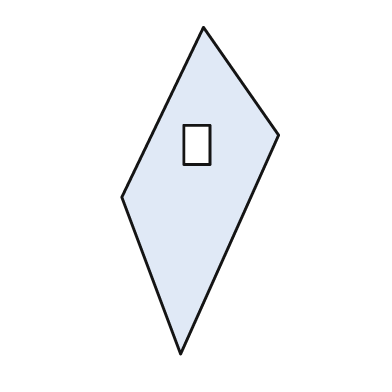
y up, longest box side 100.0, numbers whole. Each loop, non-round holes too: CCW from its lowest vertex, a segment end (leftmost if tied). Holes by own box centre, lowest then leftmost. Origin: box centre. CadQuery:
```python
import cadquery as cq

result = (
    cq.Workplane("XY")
    .moveTo(-6.0, -50.0)
    .lineTo(24.0, 17.0)
    .lineTo(1.0, 50.0)
    .lineTo(-24.0, -2.0)
    .close()
    .moveTo(-5.0, 8.0)
    .lineTo(3.0, 8.0)
    .lineTo(3.0, 20.0)
    .lineTo(-5.0, 20.0)
    .close()
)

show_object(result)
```